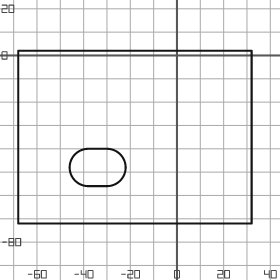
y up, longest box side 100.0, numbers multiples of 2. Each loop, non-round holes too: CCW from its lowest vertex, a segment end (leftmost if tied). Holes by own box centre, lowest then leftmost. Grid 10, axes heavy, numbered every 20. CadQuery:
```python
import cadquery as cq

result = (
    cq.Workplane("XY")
    .moveTo(-68.0, -72.0)
    .lineTo(32.0, -72.0)
    .lineTo(32.0, 2.0)
    .lineTo(-68.0, 2.0)
    .close()
    .moveTo(-38.0, -56.0)
    .lineTo(-30.0, -56.0)
    .threePointArc((-22.0, -48.0), (-30.0, -40.0))
    .lineTo(-38.0, -40.0)
    .threePointArc((-46.0, -48.0), (-38.0, -56.0))
    .close()
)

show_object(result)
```